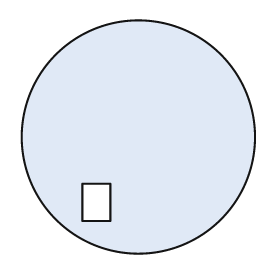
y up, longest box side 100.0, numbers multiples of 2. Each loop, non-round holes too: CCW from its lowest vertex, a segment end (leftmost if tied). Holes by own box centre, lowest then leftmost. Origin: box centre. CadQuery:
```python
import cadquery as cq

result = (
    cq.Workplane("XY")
    .moveTo(0.0, 0.0)
    .circle(50.0)
    .moveTo(-24.0, -36.0)
    .lineTo(-12.0, -36.0)
    .lineTo(-12.0, -20.0)
    .lineTo(-24.0, -20.0)
    .close()
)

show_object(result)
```